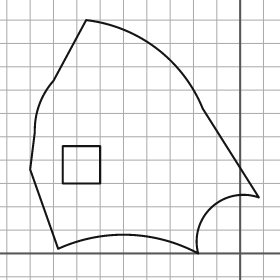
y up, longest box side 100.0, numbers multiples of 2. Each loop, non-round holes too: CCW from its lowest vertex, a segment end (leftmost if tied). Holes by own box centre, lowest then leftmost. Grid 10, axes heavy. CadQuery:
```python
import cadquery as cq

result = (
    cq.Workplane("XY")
    .moveTo(-18.0, 0.0)
    .threePointArc((-12.0, 20.0), (8.0, 24.0))
    .lineTo(-16.0, 62.0)
    .threePointArc((-36.0, 88.0), (-66.0, 100.0))
    .lineTo(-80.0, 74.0)
    .threePointArc((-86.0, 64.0), (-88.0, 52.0))
    .lineTo(-90.0, 36.0)
    .lineTo(-78.0, 2.0)
    .threePointArc((-48.0, 8.0), (-18.0, 0.0))
    .close()
    .moveTo(-76.0, 30.0)
    .lineTo(-60.0, 30.0)
    .lineTo(-60.0, 46.0)
    .lineTo(-76.0, 46.0)
    .close()
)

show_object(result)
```